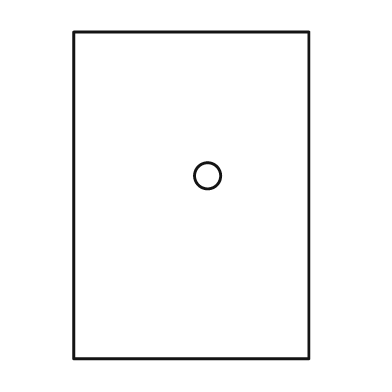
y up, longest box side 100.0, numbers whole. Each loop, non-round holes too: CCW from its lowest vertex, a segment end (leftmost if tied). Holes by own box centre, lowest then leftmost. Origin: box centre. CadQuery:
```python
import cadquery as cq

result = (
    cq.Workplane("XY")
    .moveTo(-36.0, -50.0)
    .lineTo(36.0, -50.0)
    .lineTo(36.0, 50.0)
    .lineTo(-36.0, 50.0)
    .close()
    .moveTo(5.0, 6.0)
    .circle(4.0)
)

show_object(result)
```